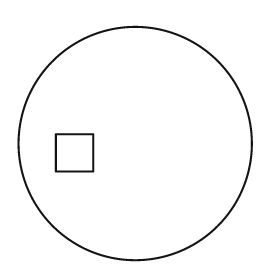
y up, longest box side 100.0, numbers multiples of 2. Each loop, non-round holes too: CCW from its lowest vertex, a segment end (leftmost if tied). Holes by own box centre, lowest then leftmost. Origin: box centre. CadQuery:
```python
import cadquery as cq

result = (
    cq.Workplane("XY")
    .moveTo(0.0, 0.0)
    .circle(50.0)
    .moveTo(-34.0, -12.0)
    .lineTo(-18.0, -12.0)
    .lineTo(-18.0, 4.0)
    .lineTo(-34.0, 4.0)
    .close()
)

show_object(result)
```